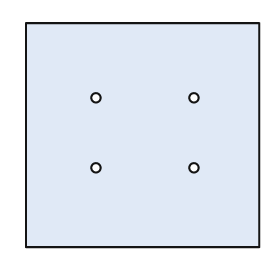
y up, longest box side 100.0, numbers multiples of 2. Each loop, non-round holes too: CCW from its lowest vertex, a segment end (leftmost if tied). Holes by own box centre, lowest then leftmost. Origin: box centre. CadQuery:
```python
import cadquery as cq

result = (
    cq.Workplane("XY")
    .moveTo(-50.0, -48.0)
    .lineTo(50.0, -48.0)
    .lineTo(50.0, 48.0)
    .lineTo(-50.0, 48.0)
    .close()
    .moveTo(-20.0, -14.0)
    .circle(2.0)
    .moveTo(22.0, -14.0)
    .circle(2.0)
    .moveTo(-20.0, 16.0)
    .circle(2.0)
    .moveTo(22.0, 16.0)
    .circle(2.0)
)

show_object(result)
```